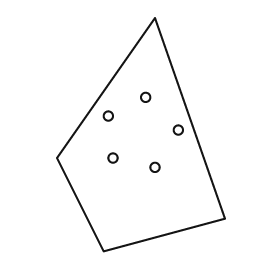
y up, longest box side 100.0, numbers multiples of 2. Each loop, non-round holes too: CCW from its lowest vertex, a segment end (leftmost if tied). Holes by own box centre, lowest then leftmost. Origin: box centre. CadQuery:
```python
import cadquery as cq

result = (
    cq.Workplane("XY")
    .moveTo(-16.0, -50.0)
    .lineTo(36.0, -36.0)
    .lineTo(6.0, 50.0)
    .lineTo(-36.0, -10.0)
    .close()
    .moveTo(6.0, -14.0)
    .circle(2.0)
    .moveTo(-12.0, -10.0)
    .circle(2.0)
    .moveTo(16.0, 2.0)
    .circle(2.0)
    .moveTo(-14.0, 8.0)
    .circle(2.0)
    .moveTo(2.0, 16.0)
    .circle(2.0)
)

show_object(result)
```